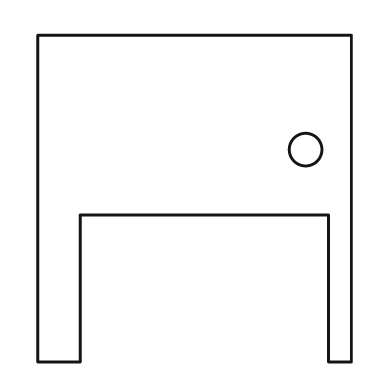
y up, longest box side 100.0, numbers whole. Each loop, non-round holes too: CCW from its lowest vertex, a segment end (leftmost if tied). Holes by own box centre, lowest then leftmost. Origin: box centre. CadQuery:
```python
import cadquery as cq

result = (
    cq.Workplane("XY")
    .moveTo(-48.0, -50.0)
    .lineTo(-35.0, -50.0)
    .lineTo(-35.0, -5.0)
    .lineTo(41.0, -5.0)
    .lineTo(41.0, -50.0)
    .lineTo(48.0, -50.0)
    .lineTo(48.0, 50.0)
    .lineTo(-48.0, 50.0)
    .close()
    .moveTo(34.0, 15.0)
    .circle(5.0)
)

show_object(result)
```